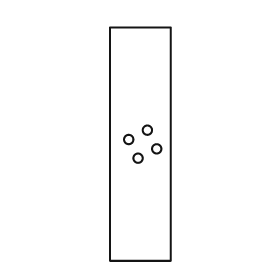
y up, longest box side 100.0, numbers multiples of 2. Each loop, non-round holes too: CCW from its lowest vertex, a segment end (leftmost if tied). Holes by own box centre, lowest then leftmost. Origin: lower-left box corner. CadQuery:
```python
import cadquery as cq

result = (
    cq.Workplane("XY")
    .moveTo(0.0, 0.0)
    .lineTo(26.0, 0.0)
    .lineTo(26.0, 100.0)
    .lineTo(0.0, 100.0)
    .close()
    .moveTo(12.0, 44.0)
    .circle(2.0)
    .moveTo(20.0, 48.0)
    .circle(2.0)
    .moveTo(8.0, 52.0)
    .circle(2.0)
    .moveTo(16.0, 56.0)
    .circle(2.0)
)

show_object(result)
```